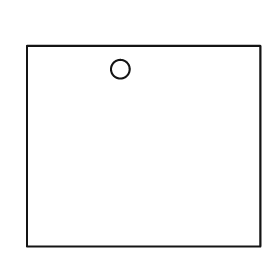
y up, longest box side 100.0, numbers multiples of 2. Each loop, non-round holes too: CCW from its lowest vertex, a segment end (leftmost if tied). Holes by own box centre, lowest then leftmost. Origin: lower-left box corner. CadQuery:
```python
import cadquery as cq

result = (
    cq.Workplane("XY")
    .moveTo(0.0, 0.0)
    .lineTo(100.0, 0.0)
    .lineTo(100.0, 86.0)
    .lineTo(0.0, 86.0)
    .close()
    .moveTo(40.0, 76.0)
    .circle(4.0)
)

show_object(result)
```